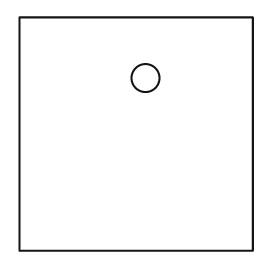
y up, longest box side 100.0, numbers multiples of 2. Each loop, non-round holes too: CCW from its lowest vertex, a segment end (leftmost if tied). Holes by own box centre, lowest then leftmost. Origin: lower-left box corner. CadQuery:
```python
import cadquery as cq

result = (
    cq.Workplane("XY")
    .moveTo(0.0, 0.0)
    .lineTo(100.0, 0.0)
    .lineTo(100.0, 100.0)
    .lineTo(0.0, 100.0)
    .close()
    .moveTo(54.0, 74.0)
    .circle(6.0)
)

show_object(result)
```